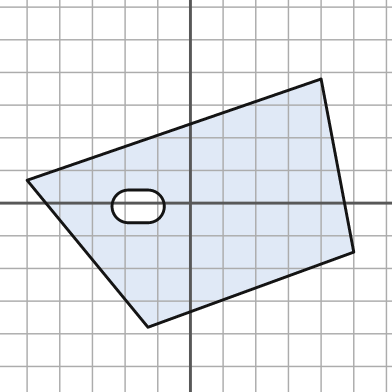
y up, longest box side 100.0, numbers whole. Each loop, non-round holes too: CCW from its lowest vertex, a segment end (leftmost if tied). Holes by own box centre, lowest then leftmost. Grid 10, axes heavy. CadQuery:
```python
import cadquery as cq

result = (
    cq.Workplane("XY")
    .moveTo(-13.0, -38.0)
    .lineTo(50.0, -15.0)
    .lineTo(40.0, 38.0)
    .lineTo(-50.0, 7.0)
    .close()
    .moveTo(-19.0, -6.0)
    .lineTo(-13.0, -6.0)
    .threePointArc((-8.0, -1.0), (-13.0, 4.0))
    .lineTo(-19.0, 4.0)
    .threePointArc((-24.0, -1.0), (-19.0, -6.0))
    .close()
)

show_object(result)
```